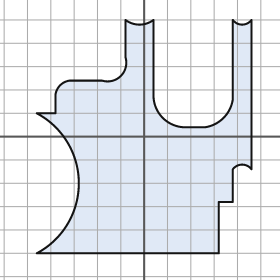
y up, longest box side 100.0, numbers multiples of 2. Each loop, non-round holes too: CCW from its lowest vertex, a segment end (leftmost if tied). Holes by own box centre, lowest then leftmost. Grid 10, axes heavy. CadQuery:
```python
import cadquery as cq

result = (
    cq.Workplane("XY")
    .moveTo(-46.0, -50.0)
    .lineTo(32.0, -50.0)
    .lineTo(32.0, -28.0)
    .lineTo(38.0, -28.0)
    .lineTo(38.0, -14.0)
    .threePointArc((42.0, -12.0), (46.0, -14.0))
    .lineTo(46.0, 50.0)
    .threePointArc((42.0, 48.0), (38.0, 50.0))
    .lineTo(38.0, 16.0)
    .threePointArc((34.0, 8.0), (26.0, 4.0))
    .lineTo(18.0, 4.0)
    .threePointArc((8.0, 8.0), (4.0, 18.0))
    .lineTo(4.0, 50.0)
    .threePointArc((-2.0, 48.0), (-8.0, 50.0))
    .lineTo(-8.0, 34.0)
    .threePointArc((-10.0, 26.0), (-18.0, 24.0))
    .lineTo(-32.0, 24.0)
    .threePointArc((-36.0, 22.0), (-38.0, 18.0))
    .lineTo(-38.0, 10.0)
    .lineTo(-46.0, 10.0)
    .threePointArc((-28.0, -20.0), (-46.0, -50.0))
    .close()
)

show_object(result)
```